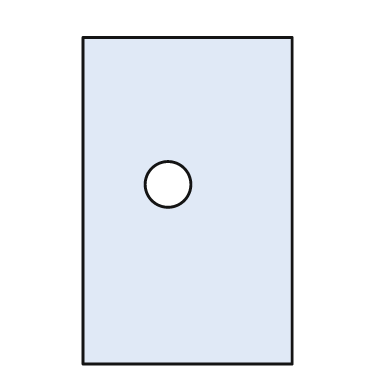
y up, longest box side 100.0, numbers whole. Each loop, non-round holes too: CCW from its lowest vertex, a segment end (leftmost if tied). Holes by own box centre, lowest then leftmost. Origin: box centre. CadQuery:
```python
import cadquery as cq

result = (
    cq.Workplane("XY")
    .moveTo(-32.0, -50.0)
    .lineTo(32.0, -50.0)
    .lineTo(32.0, 50.0)
    .lineTo(-32.0, 50.0)
    .close()
    .moveTo(-6.0, 5.0)
    .circle(7.0)
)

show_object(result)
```